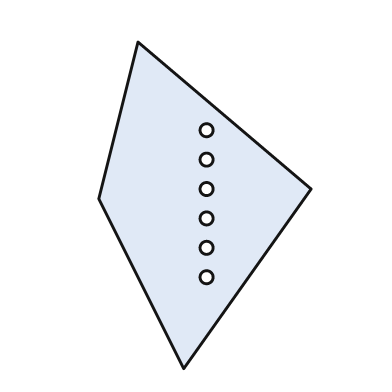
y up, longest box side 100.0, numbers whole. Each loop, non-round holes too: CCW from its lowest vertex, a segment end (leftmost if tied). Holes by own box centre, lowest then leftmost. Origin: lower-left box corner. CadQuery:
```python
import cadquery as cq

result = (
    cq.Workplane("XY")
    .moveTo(26.0, 0.0)
    .lineTo(65.0, 55.0)
    .lineTo(12.0, 100.0)
    .lineTo(0.0, 52.0)
    .close()
    .moveTo(33.0, 28.0)
    .circle(2.0)
    .moveTo(33.0, 37.0)
    .circle(2.0)
    .moveTo(33.0, 46.0)
    .circle(2.0)
    .moveTo(33.0, 55.0)
    .circle(2.0)
    .moveTo(33.0, 64.0)
    .circle(2.0)
    .moveTo(33.0, 73.0)
    .circle(2.0)
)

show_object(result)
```